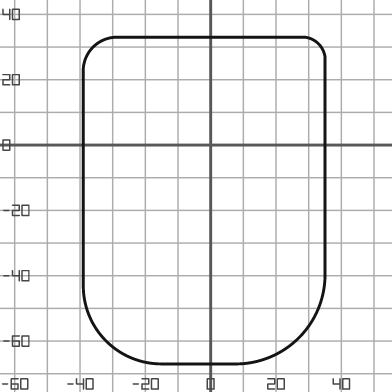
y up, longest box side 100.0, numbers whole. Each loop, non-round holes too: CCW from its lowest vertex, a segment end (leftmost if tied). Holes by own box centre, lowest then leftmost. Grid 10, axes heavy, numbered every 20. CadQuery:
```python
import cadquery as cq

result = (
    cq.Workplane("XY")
    .moveTo(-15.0, -67.0)
    .lineTo(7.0, -67.0)
    .threePointArc((27.0, -59.0), (35.0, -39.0))
    .lineTo(35.0, 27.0)
    .threePointArc((33.0, 31.0), (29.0, 33.0))
    .lineTo(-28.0, 33.0)
    .threePointArc((-36.0, 30.0), (-39.0, 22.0))
    .lineTo(-39.0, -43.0)
    .threePointArc((-32.0, -60.0), (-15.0, -67.0))
    .close()
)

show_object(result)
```